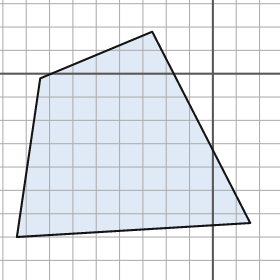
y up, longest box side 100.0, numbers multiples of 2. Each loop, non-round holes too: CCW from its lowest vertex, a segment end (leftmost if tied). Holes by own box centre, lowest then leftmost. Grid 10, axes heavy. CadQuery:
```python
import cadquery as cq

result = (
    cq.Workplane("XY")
    .moveTo(-84.0, -70.0)
    .lineTo(16.0, -64.0)
    .lineTo(-26.0, 18.0)
    .lineTo(-74.0, -2.0)
    .close()
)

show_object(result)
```